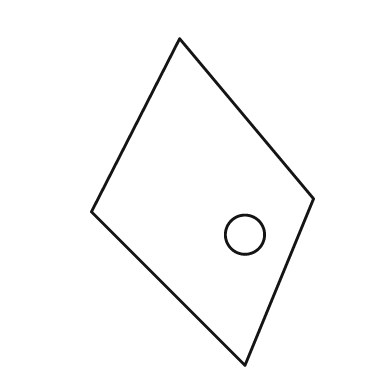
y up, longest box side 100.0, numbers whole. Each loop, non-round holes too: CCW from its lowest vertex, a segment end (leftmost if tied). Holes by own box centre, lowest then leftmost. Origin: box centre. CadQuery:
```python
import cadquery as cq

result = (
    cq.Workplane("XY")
    .moveTo(13.0, -50.0)
    .lineTo(34.0, 1.0)
    .lineTo(-7.0, 50.0)
    .lineTo(-34.0, -3.0)
    .close()
    .moveTo(13.0, -10.0)
    .circle(6.0)
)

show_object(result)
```